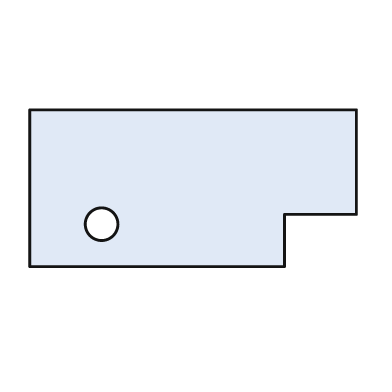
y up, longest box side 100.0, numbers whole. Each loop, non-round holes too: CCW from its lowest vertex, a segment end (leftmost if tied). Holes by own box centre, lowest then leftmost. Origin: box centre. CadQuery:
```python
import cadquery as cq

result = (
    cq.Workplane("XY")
    .moveTo(-50.0, -24.0)
    .lineTo(28.0, -24.0)
    .lineTo(28.0, -8.0)
    .lineTo(50.0, -8.0)
    .lineTo(50.0, 24.0)
    .lineTo(-50.0, 24.0)
    .close()
    .moveTo(-28.0, -11.0)
    .circle(5.0)
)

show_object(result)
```